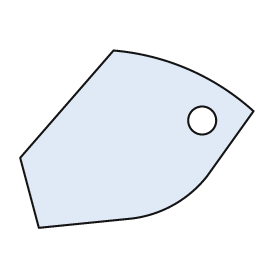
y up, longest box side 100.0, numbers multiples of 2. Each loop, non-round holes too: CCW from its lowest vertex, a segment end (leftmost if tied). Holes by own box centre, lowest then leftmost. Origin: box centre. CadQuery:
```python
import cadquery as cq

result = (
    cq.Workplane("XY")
    .moveTo(-42.0, -38.0)
    .lineTo(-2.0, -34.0)
    .threePointArc((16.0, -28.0), (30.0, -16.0))
    .lineTo(50.0, 12.0)
    .threePointArc((22.0, 30.0), (-10.0, 38.0))
    .lineTo(-50.0, -8.0)
    .close()
    .moveTo(28.0, 8.0)
    .circle(6.0)
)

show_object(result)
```